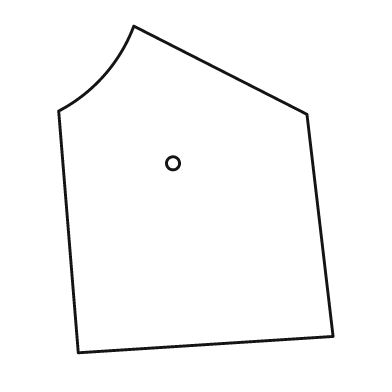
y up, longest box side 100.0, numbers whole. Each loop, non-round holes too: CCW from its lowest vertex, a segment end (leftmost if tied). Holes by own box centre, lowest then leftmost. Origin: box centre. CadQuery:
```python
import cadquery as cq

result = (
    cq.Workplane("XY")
    .moveTo(-36.0, -50.0)
    .lineTo(42.0, -45.0)
    .lineTo(34.0, 23.0)
    .lineTo(-19.0, 50.0)
    .threePointArc((-28.0, 35.0), (-42.0, 24.0))
    .close()
    .moveTo(-7.0, 8.0)
    .circle(2.0)
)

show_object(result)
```